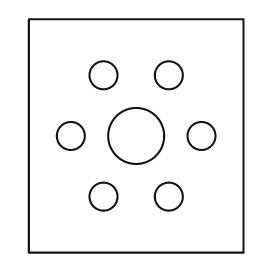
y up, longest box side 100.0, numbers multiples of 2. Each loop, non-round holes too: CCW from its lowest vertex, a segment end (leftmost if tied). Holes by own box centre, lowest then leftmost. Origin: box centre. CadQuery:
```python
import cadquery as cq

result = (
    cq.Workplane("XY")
    .moveTo(-46.0, -50.0)
    .lineTo(46.0, -50.0)
    .lineTo(46.0, 50.0)
    .lineTo(-46.0, 50.0)
    .close()
    .moveTo(-14.0, -26.0)
    .circle(6.0)
    .moveTo(14.0, -26.0)
    .circle(6.0)
    .moveTo(-28.0, 0.0)
    .circle(6.0)
    .moveTo(0.0, 0.0)
    .circle(12.0)
    .moveTo(28.0, 0.0)
    .circle(6.0)
    .moveTo(-14.0, 26.0)
    .circle(6.0)
    .moveTo(14.0, 26.0)
    .circle(6.0)
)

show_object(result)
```